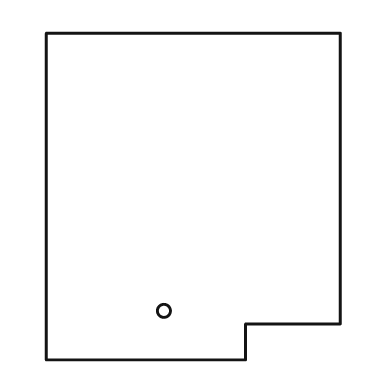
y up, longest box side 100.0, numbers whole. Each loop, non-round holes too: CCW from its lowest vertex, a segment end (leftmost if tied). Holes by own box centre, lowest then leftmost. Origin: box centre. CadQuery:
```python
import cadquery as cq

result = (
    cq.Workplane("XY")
    .moveTo(-45.0, -50.0)
    .lineTo(16.0, -50.0)
    .lineTo(16.0, -39.0)
    .lineTo(45.0, -39.0)
    .lineTo(45.0, 50.0)
    .lineTo(-45.0, 50.0)
    .close()
    .moveTo(-9.0, -35.0)
    .circle(2.0)
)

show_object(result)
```